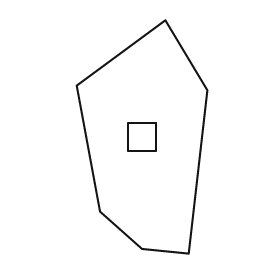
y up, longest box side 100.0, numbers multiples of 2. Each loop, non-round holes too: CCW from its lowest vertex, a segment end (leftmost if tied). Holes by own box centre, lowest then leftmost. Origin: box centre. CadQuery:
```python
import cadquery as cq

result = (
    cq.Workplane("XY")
    .moveTo(20.0, -50.0)
    .lineTo(28.0, 20.0)
    .lineTo(10.0, 50.0)
    .lineTo(-28.0, 22.0)
    .lineTo(-18.0, -32.0)
    .lineTo(0.0, -48.0)
    .close()
    .moveTo(-6.0, -6.0)
    .lineTo(6.0, -6.0)
    .lineTo(6.0, 6.0)
    .lineTo(-6.0, 6.0)
    .close()
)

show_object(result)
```